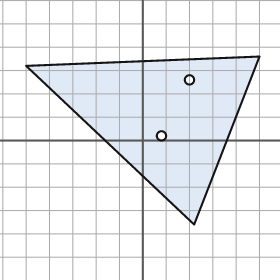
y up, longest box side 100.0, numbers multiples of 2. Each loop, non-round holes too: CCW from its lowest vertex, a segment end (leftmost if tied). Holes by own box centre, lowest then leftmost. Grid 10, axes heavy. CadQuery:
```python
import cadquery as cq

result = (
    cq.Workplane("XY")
    .moveTo(22.0, -36.0)
    .lineTo(50.0, 36.0)
    .lineTo(-50.0, 32.0)
    .close()
    .moveTo(8.0, 2.0)
    .circle(2.0)
    .moveTo(20.0, 26.0)
    .circle(2.0)
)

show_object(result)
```